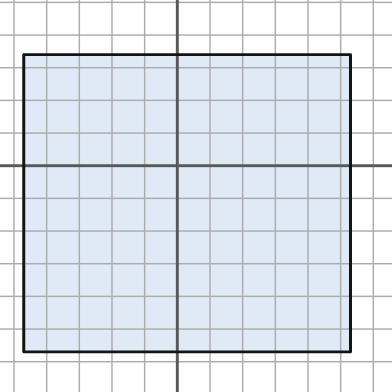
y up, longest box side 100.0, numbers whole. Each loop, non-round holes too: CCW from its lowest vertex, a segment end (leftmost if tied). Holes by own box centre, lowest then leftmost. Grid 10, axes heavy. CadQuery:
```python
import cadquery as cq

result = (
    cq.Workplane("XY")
    .moveTo(-47.0, -57.0)
    .lineTo(53.0, -57.0)
    .lineTo(53.0, 34.0)
    .lineTo(-47.0, 34.0)
    .close()
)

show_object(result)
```